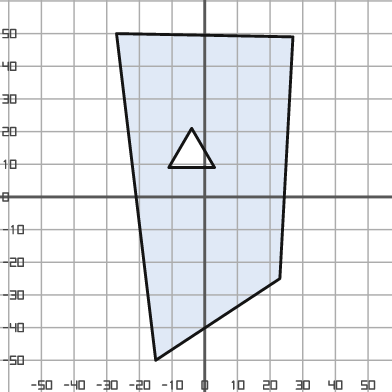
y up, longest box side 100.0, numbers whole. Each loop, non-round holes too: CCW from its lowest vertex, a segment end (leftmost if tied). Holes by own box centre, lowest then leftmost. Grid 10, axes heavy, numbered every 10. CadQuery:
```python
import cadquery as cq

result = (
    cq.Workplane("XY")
    .moveTo(-15.0, -50.0)
    .lineTo(23.0, -25.0)
    .lineTo(27.0, 49.0)
    .lineTo(-27.0, 50.0)
    .close()
    .moveTo(-11.0, 9.0)
    .lineTo(3.0, 9.0)
    .lineTo(-4.0, 21.0)
    .close()
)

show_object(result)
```